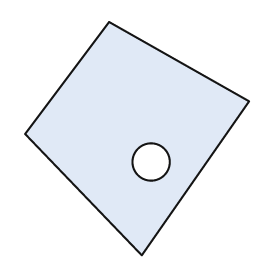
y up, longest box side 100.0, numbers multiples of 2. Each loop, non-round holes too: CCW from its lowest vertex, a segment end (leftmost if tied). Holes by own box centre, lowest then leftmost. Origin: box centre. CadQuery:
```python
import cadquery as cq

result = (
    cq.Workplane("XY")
    .moveTo(2.0, -50.0)
    .lineTo(48.0, 16.0)
    .lineTo(-12.0, 50.0)
    .lineTo(-48.0, 2.0)
    .close()
    .moveTo(6.0, -10.0)
    .circle(8.0)
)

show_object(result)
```